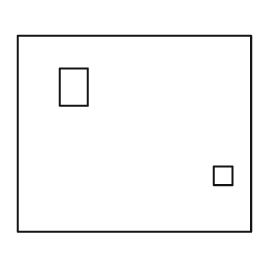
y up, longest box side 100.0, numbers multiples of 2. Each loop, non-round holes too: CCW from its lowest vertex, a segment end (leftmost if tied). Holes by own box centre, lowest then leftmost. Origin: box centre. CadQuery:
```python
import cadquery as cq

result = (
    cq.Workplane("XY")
    .moveTo(-50.0, -42.0)
    .lineTo(50.0, -42.0)
    .lineTo(50.0, 42.0)
    .lineTo(-50.0, 42.0)
    .close()
    .moveTo(34.0, -22.0)
    .lineTo(42.0, -22.0)
    .lineTo(42.0, -14.0)
    .lineTo(34.0, -14.0)
    .close()
    .moveTo(-32.0, 12.0)
    .lineTo(-20.0, 12.0)
    .lineTo(-20.0, 28.0)
    .lineTo(-32.0, 28.0)
    .close()
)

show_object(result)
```